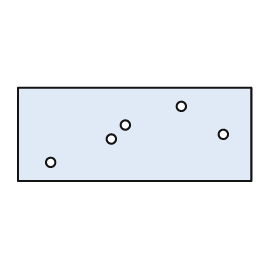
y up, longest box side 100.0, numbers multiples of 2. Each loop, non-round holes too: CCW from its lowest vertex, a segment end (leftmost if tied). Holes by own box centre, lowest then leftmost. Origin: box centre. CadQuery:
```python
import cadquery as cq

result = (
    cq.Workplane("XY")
    .moveTo(-50.0, -20.0)
    .lineTo(50.0, -20.0)
    .lineTo(50.0, 20.0)
    .lineTo(-50.0, 20.0)
    .close()
    .moveTo(-36.0, -12.0)
    .circle(2.0)
    .moveTo(-10.0, -2.0)
    .circle(2.0)
    .moveTo(38.0, 0.0)
    .circle(2.0)
    .moveTo(-4.0, 4.0)
    .circle(2.0)
    .moveTo(20.0, 12.0)
    .circle(2.0)
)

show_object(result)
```